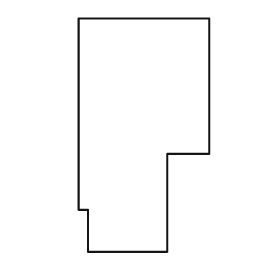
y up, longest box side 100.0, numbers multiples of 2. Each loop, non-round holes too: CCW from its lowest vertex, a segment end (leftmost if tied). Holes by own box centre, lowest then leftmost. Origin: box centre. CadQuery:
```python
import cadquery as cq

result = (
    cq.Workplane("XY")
    .moveTo(-24.0, -50.0)
    .lineTo(10.0, -50.0)
    .lineTo(10.0, -8.0)
    .lineTo(28.0, -8.0)
    .lineTo(28.0, 50.0)
    .lineTo(-28.0, 50.0)
    .lineTo(-28.0, -32.0)
    .lineTo(-24.0, -32.0)
    .close()
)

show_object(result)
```